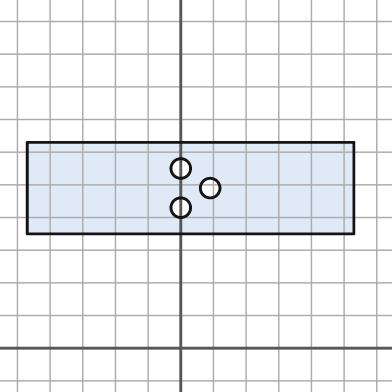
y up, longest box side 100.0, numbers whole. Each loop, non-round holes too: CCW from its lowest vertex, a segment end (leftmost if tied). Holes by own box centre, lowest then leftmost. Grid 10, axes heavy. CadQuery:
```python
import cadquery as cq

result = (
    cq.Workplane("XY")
    .moveTo(-47.0, 35.0)
    .lineTo(53.0, 35.0)
    .lineTo(53.0, 63.0)
    .lineTo(-47.0, 63.0)
    .close()
    .moveTo(0.0, 43.0)
    .circle(3.0)
    .moveTo(9.0, 49.0)
    .circle(3.0)
    .moveTo(0.0, 55.0)
    .circle(3.0)
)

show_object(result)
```